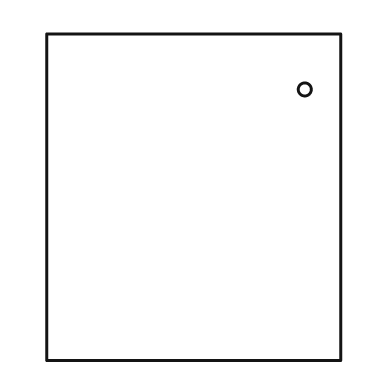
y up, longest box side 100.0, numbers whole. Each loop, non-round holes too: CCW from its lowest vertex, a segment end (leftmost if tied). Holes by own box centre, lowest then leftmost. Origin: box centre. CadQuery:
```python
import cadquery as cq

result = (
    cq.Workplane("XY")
    .moveTo(-45.0, -50.0)
    .lineTo(45.0, -50.0)
    .lineTo(45.0, 50.0)
    .lineTo(-45.0, 50.0)
    .close()
    .moveTo(34.0, 33.0)
    .circle(2.0)
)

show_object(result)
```